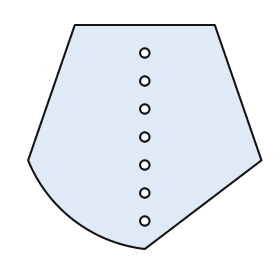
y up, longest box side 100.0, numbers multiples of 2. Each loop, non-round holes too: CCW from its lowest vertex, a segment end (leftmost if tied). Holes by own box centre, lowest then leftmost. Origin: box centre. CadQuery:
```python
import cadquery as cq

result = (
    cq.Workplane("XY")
    .moveTo(0.0, -48.0)
    .lineTo(50.0, -10.0)
    .lineTo(30.0, 48.0)
    .lineTo(-30.0, 48.0)
    .lineTo(-50.0, -10.0)
    .threePointArc((-30.0, -36.0), (0.0, -48.0))
    .close()
    .moveTo(0.0, -36.0)
    .circle(2.0)
    .moveTo(0.0, -24.0)
    .circle(2.0)
    .moveTo(0.0, -12.0)
    .circle(2.0)
    .moveTo(0.0, 0.0)
    .circle(2.0)
    .moveTo(0.0, 12.0)
    .circle(2.0)
    .moveTo(0.0, 24.0)
    .circle(2.0)
    .moveTo(0.0, 36.0)
    .circle(2.0)
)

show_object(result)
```